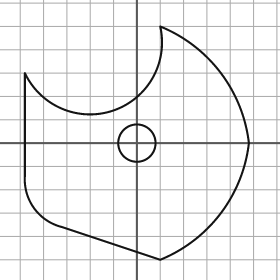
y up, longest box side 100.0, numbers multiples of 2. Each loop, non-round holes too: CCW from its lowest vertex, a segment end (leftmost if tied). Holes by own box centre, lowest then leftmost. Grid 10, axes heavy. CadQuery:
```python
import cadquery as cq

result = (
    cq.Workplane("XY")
    .moveTo(10.0, -50.0)
    .threePointArc((36.0, -30.0), (48.0, 0.0))
    .threePointArc((36.0, 30.0), (10.0, 50.0))
    .threePointArc((-10.0, 14.0), (-48.0, 30.0))
    .lineTo(-48.0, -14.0)
    .threePointArc((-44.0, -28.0), (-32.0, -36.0))
    .close()
    .moveTo(0.0, 0.0)
    .circle(8.0)
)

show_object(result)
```